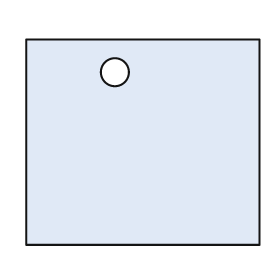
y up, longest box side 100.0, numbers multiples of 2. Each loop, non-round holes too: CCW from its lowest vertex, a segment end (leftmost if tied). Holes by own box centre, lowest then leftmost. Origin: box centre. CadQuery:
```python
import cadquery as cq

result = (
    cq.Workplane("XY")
    .moveTo(-50.0, -44.0)
    .lineTo(50.0, -44.0)
    .lineTo(50.0, 44.0)
    .lineTo(-50.0, 44.0)
    .close()
    .moveTo(-12.0, 30.0)
    .circle(6.0)
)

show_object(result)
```